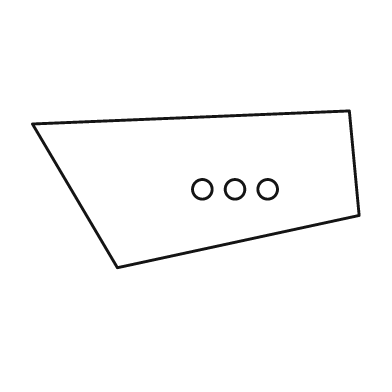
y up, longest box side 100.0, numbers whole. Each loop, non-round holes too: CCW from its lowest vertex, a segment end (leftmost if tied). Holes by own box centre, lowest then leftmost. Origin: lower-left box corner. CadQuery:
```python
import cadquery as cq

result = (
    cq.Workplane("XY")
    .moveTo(26.0, 0.0)
    .lineTo(100.0, 16.0)
    .lineTo(97.0, 48.0)
    .lineTo(0.0, 44.0)
    .close()
    .moveTo(52.0, 24.0)
    .circle(3.0)
    .moveTo(62.0, 24.0)
    .circle(3.0)
    .moveTo(72.0, 24.0)
    .circle(3.0)
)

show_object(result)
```